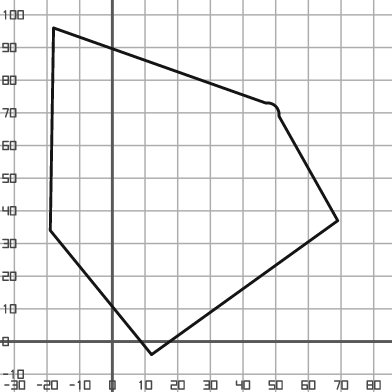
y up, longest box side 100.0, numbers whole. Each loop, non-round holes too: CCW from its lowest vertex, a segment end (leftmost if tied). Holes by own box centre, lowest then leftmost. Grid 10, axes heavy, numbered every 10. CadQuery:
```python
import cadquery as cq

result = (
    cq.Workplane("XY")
    .moveTo(12.0, -4.0)
    .lineTo(69.0, 37.0)
    .lineTo(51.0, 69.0)
    .threePointArc((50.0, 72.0), (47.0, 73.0))
    .lineTo(-18.0, 96.0)
    .lineTo(-19.0, 34.0)
    .close()
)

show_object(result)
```